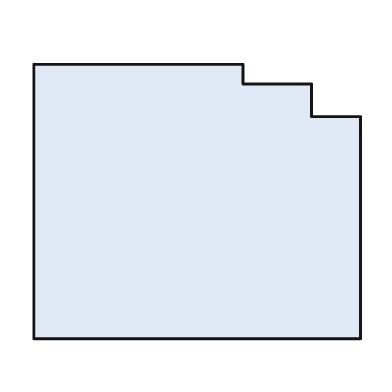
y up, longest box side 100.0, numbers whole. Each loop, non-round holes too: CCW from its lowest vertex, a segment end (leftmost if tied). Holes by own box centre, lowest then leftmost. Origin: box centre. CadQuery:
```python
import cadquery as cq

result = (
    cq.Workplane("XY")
    .moveTo(-50.0, -42.0)
    .lineTo(50.0, -42.0)
    .lineTo(50.0, 26.0)
    .lineTo(35.0, 26.0)
    .lineTo(35.0, 36.0)
    .lineTo(14.0, 36.0)
    .lineTo(14.0, 42.0)
    .lineTo(-50.0, 42.0)
    .close()
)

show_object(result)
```